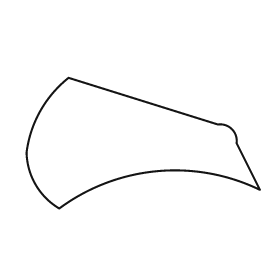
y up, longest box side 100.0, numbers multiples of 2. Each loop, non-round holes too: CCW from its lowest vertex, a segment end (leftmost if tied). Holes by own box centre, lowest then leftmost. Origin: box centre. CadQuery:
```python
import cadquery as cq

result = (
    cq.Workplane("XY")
    .moveTo(-36.0, -28.0)
    .threePointArc((6.0, -12.0), (50.0, -20.0))
    .lineTo(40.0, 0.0)
    .threePointArc((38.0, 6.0), (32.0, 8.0))
    .lineTo(-32.0, 28.0)
    .threePointArc((-44.0, 14.0), (-50.0, -4.0))
    .threePointArc((-46.0, -18.0), (-36.0, -28.0))
    .close()
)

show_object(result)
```